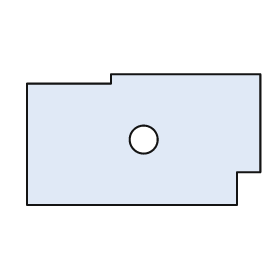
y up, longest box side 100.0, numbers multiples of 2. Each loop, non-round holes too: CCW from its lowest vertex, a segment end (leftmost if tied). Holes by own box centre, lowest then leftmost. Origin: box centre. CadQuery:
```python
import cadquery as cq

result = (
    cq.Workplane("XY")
    .moveTo(-50.0, -28.0)
    .lineTo(40.0, -28.0)
    .lineTo(40.0, -14.0)
    .lineTo(50.0, -14.0)
    .lineTo(50.0, 28.0)
    .lineTo(-14.0, 28.0)
    .lineTo(-14.0, 24.0)
    .lineTo(-50.0, 24.0)
    .close()
    .moveTo(0.0, 0.0)
    .circle(6.0)
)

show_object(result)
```